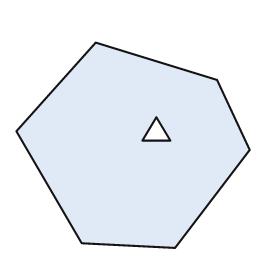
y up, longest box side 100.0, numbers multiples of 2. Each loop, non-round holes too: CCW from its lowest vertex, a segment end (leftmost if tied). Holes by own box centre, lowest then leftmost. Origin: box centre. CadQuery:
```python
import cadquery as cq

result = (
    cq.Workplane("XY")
    .moveTo(18.0, -44.0)
    .lineTo(50.0, -2.0)
    .lineTo(36.0, 28.0)
    .lineTo(-16.0, 44.0)
    .lineTo(-50.0, 6.0)
    .lineTo(-22.0, -42.0)
    .close()
    .moveTo(4.0, 2.0)
    .lineTo(16.0, 2.0)
    .lineTo(10.0, 12.0)
    .close()
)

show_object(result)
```